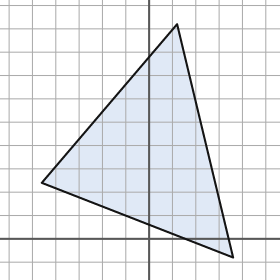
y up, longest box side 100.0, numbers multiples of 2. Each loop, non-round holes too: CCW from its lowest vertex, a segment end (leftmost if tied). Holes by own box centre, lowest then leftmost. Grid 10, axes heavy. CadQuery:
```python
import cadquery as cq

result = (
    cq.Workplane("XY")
    .moveTo(36.0, -8.0)
    .lineTo(12.0, 92.0)
    .lineTo(-46.0, 24.0)
    .close()
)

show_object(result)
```